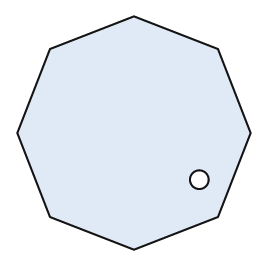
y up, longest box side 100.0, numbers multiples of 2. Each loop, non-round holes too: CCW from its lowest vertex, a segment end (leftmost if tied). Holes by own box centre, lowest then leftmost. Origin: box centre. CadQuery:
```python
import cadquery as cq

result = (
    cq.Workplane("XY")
    .moveTo(0.0, -50.0)
    .lineTo(36.0, -36.0)
    .lineTo(50.0, 0.0)
    .lineTo(36.0, 36.0)
    .lineTo(0.0, 50.0)
    .lineTo(-36.0, 36.0)
    .lineTo(-50.0, 0.0)
    .lineTo(-36.0, -36.0)
    .close()
    .moveTo(28.0, -20.0)
    .circle(4.0)
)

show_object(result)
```